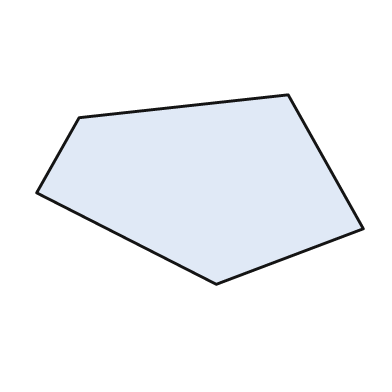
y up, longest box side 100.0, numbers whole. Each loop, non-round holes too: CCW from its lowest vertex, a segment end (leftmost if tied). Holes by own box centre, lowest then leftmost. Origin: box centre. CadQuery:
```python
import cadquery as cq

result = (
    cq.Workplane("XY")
    .moveTo(5.0, -29.0)
    .lineTo(50.0, -12.0)
    .lineTo(27.0, 29.0)
    .lineTo(-37.0, 22.0)
    .lineTo(-50.0, -1.0)
    .close()
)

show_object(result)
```